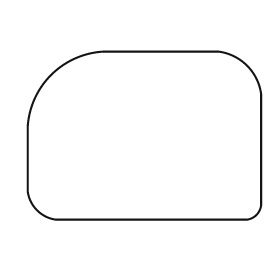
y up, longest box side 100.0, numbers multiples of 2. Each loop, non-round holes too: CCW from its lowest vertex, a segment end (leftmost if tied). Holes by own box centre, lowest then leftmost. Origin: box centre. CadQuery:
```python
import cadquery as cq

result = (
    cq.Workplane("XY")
    .moveTo(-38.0, -36.0)
    .lineTo(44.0, -36.0)
    .threePointArc((48.0, -34.0), (50.0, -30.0))
    .lineTo(50.0, 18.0)
    .threePointArc((44.0, 30.0), (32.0, 36.0))
    .lineTo(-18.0, 36.0)
    .threePointArc((-40.0, 26.0), (-50.0, 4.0))
    .lineTo(-50.0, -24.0)
    .threePointArc((-46.0, -32.0), (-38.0, -36.0))
    .close()
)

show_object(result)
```